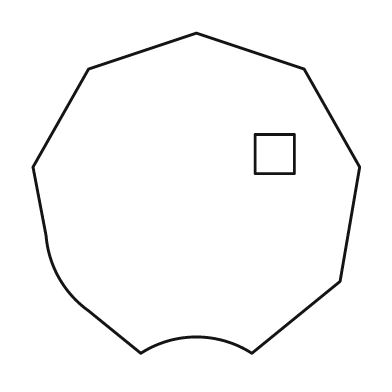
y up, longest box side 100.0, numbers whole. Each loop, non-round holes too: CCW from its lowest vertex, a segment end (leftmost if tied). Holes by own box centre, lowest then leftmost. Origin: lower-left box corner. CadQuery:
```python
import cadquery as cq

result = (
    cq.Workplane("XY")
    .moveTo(33.0, 0.0)
    .threePointArc((50.0, 5.0), (67.0, 0.0))
    .lineTo(94.0, 22.0)
    .lineTo(100.0, 57.0)
    .lineTo(83.0, 87.0)
    .lineTo(50.0, 98.0)
    .lineTo(17.0, 87.0)
    .lineTo(0.0, 57.0)
    .lineTo(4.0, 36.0)
    .threePointArc((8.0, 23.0), (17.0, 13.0))
    .close()
    .moveTo(68.0, 55.0)
    .lineTo(80.0, 55.0)
    .lineTo(80.0, 67.0)
    .lineTo(68.0, 67.0)
    .close()
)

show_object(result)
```